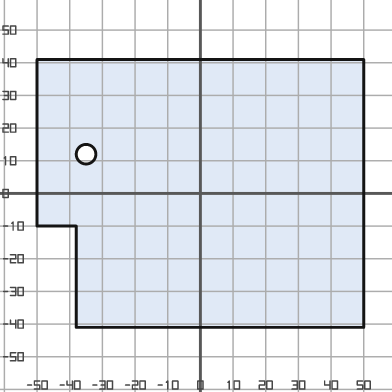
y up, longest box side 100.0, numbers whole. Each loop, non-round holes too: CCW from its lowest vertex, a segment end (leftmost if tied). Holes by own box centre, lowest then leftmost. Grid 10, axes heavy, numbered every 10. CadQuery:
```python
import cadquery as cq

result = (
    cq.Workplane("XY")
    .moveTo(-38.0, -41.0)
    .lineTo(50.0, -41.0)
    .lineTo(50.0, 41.0)
    .lineTo(-50.0, 41.0)
    .lineTo(-50.0, -10.0)
    .lineTo(-38.0, -10.0)
    .close()
    .moveTo(-35.0, 12.0)
    .circle(3.0)
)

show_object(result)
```